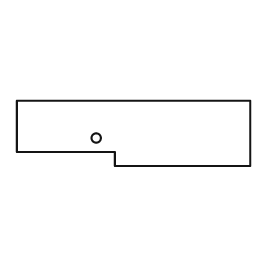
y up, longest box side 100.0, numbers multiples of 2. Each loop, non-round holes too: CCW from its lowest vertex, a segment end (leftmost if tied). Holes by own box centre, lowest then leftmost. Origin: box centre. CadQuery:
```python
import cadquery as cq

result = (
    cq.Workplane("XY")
    .moveTo(-8.0, -14.0)
    .lineTo(50.0, -14.0)
    .lineTo(50.0, 14.0)
    .lineTo(-50.0, 14.0)
    .lineTo(-50.0, -8.0)
    .lineTo(-8.0, -8.0)
    .close()
    .moveTo(-16.0, -2.0)
    .circle(2.0)
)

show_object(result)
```